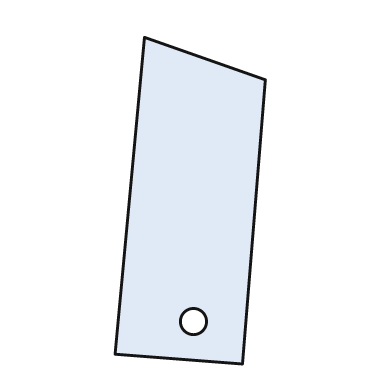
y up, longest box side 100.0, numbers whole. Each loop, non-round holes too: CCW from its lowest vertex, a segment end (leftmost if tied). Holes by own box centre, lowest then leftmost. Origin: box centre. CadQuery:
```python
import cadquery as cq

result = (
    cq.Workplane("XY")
    .moveTo(16.0, -50.0)
    .lineTo(23.0, 37.0)
    .lineTo(-14.0, 50.0)
    .lineTo(-23.0, -47.0)
    .close()
    .moveTo(1.0, -37.0)
    .circle(4.0)
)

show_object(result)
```